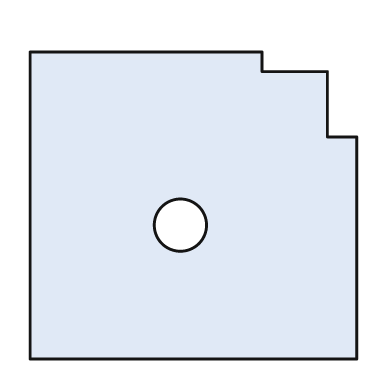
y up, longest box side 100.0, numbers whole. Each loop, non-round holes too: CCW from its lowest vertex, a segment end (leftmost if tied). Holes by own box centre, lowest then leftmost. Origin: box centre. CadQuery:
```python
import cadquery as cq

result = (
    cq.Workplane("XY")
    .moveTo(-50.0, -47.0)
    .lineTo(50.0, -47.0)
    .lineTo(50.0, 21.0)
    .lineTo(41.0, 21.0)
    .lineTo(41.0, 41.0)
    .lineTo(21.0, 41.0)
    .lineTo(21.0, 47.0)
    .lineTo(-50.0, 47.0)
    .close()
    .moveTo(-4.0, -6.0)
    .circle(8.0)
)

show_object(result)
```